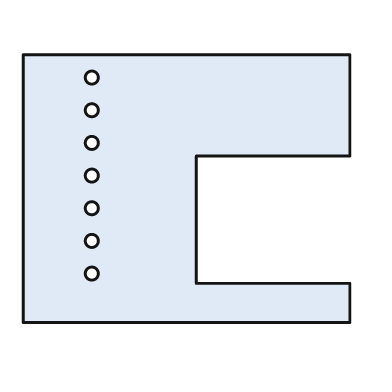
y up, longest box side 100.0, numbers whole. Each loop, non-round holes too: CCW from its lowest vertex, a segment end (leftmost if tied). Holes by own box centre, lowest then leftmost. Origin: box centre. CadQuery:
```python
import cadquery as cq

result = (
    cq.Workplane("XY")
    .moveTo(-50.0, -41.0)
    .lineTo(50.0, -41.0)
    .lineTo(50.0, -29.0)
    .lineTo(3.0, -29.0)
    .lineTo(3.0, 10.0)
    .lineTo(50.0, 10.0)
    .lineTo(50.0, 41.0)
    .lineTo(-50.0, 41.0)
    .close()
    .moveTo(-29.0, -26.0)
    .circle(2.0)
    .moveTo(-29.0, -16.0)
    .circle(2.0)
    .moveTo(-29.0, -6.0)
    .circle(2.0)
    .moveTo(-29.0, 4.0)
    .circle(2.0)
    .moveTo(-29.0, 14.0)
    .circle(2.0)
    .moveTo(-29.0, 24.0)
    .circle(2.0)
    .moveTo(-29.0, 34.0)
    .circle(2.0)
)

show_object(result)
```